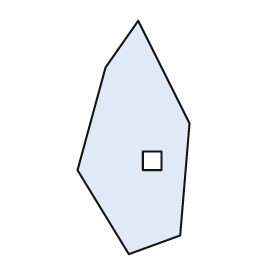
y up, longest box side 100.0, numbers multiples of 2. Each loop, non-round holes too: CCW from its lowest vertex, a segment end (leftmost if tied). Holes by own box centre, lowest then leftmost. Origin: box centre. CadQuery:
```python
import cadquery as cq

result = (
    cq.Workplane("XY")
    .moveTo(-2.0, -50.0)
    .lineTo(20.0, -42.0)
    .lineTo(24.0, 6.0)
    .lineTo(2.0, 50.0)
    .lineTo(-12.0, 30.0)
    .lineTo(-24.0, -14.0)
    .close()
    .moveTo(4.0, -14.0)
    .lineTo(12.0, -14.0)
    .lineTo(12.0, -6.0)
    .lineTo(4.0, -6.0)
    .close()
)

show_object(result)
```